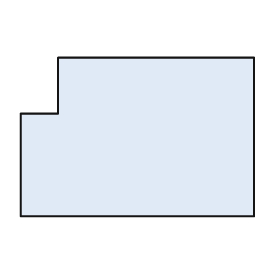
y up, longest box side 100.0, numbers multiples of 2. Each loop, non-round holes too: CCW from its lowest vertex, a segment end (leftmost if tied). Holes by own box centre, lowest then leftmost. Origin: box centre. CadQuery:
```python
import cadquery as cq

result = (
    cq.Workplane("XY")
    .moveTo(-50.0, -34.0)
    .lineTo(50.0, -34.0)
    .lineTo(50.0, 34.0)
    .lineTo(-34.0, 34.0)
    .lineTo(-34.0, 10.0)
    .lineTo(-50.0, 10.0)
    .close()
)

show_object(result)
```